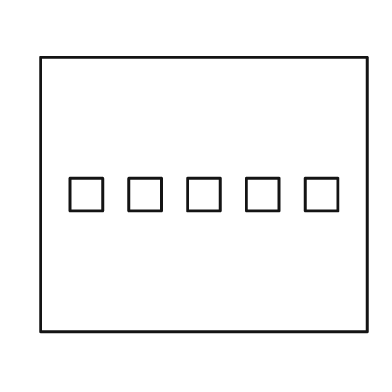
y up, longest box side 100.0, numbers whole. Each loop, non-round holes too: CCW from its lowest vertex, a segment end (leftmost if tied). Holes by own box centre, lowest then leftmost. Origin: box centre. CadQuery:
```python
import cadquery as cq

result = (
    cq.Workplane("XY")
    .moveTo(-50.0, -42.0)
    .lineTo(50.0, -42.0)
    .lineTo(50.0, 42.0)
    .lineTo(-50.0, 42.0)
    .close()
    .moveTo(-41.0, -5.0)
    .lineTo(-31.0, -5.0)
    .lineTo(-31.0, 5.0)
    .lineTo(-41.0, 5.0)
    .close()
    .moveTo(-23.0, -5.0)
    .lineTo(-13.0, -5.0)
    .lineTo(-13.0, 5.0)
    .lineTo(-23.0, 5.0)
    .close()
    .moveTo(-5.0, -5.0)
    .lineTo(5.0, -5.0)
    .lineTo(5.0, 5.0)
    .lineTo(-5.0, 5.0)
    .close()
    .moveTo(13.0, -5.0)
    .lineTo(23.0, -5.0)
    .lineTo(23.0, 5.0)
    .lineTo(13.0, 5.0)
    .close()
    .moveTo(31.0, -5.0)
    .lineTo(41.0, -5.0)
    .lineTo(41.0, 5.0)
    .lineTo(31.0, 5.0)
    .close()
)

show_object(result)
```